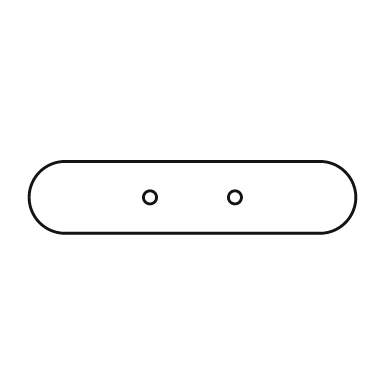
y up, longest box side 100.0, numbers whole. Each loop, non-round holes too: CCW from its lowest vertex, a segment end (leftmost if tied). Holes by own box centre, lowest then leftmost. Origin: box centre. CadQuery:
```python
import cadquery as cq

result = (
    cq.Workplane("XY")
    .moveTo(-39.0, -11.0)
    .lineTo(39.0, -11.0)
    .threePointArc((50.0, 0.0), (39.0, 11.0))
    .lineTo(-39.0, 11.0)
    .threePointArc((-50.0, 0.0), (-39.0, -11.0))
    .close()
    .moveTo(-13.0, 0.0)
    .circle(2.0)
    .moveTo(13.0, 0.0)
    .circle(2.0)
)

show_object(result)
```